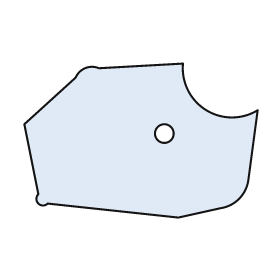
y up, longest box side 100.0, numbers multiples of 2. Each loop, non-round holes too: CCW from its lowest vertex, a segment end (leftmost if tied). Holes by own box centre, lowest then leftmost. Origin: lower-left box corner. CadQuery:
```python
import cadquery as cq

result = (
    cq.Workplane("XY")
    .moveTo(66.0, 0.0)
    .lineTo(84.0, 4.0)
    .threePointArc((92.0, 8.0), (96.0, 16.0))
    .lineTo(100.0, 46.0)
    .threePointArc((78.0, 46.0), (68.0, 66.0))
    .lineTo(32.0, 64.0)
    .threePointArc((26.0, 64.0), (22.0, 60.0))
    .lineTo(0.0, 40.0)
    .lineTo(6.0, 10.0)
    .threePointArc((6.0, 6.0), (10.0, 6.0))
    .close()
    .moveTo(60.0, 36.0)
    .circle(4.0)
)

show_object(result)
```